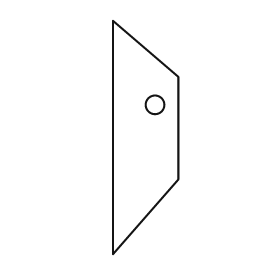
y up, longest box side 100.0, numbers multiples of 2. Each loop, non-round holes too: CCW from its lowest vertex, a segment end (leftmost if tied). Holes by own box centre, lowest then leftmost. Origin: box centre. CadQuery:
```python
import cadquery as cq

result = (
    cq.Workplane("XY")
    .moveTo(-14.0, -50.0)
    .lineTo(14.0, -18.0)
    .lineTo(14.0, 26.0)
    .lineTo(-14.0, 50.0)
    .close()
    .moveTo(4.0, 14.0)
    .circle(4.0)
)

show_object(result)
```